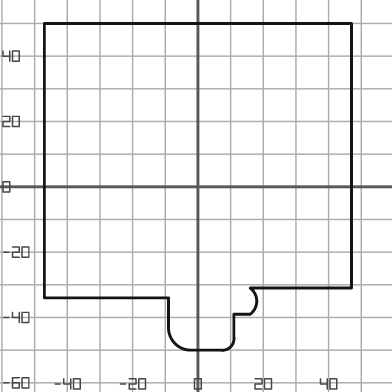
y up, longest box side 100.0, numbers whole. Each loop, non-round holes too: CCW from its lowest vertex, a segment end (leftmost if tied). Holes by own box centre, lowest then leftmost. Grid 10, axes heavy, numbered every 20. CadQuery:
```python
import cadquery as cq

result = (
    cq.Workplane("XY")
    .moveTo(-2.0, -50.0)
    .lineTo(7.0, -50.0)
    .threePointArc((10.0, -49.0), (11.0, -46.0))
    .lineTo(11.0, -39.0)
    .lineTo(16.0, -39.0)
    .threePointArc((18.0, -35.0), (16.0, -31.0))
    .lineTo(47.0, -31.0)
    .lineTo(47.0, 50.0)
    .lineTo(-47.0, 50.0)
    .lineTo(-47.0, -34.0)
    .lineTo(-9.0, -34.0)
    .lineTo(-9.0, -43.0)
    .threePointArc((-7.0, -48.0), (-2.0, -50.0))
    .close()
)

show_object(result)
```